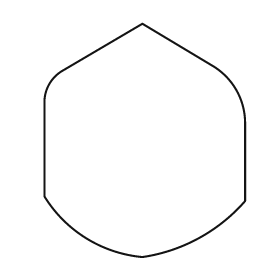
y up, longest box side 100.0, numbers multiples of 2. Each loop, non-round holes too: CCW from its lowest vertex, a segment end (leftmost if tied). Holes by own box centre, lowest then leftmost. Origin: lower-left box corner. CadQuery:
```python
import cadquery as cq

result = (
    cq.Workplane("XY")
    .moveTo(42.0, 0.0)
    .threePointArc((66.0, 8.0), (86.0, 24.0))
    .lineTo(86.0, 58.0)
    .threePointArc((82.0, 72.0), (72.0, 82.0))
    .lineTo(42.0, 100.0)
    .lineTo(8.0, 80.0)
    .threePointArc((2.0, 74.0), (0.0, 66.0))
    .lineTo(0.0, 26.0)
    .threePointArc((18.0, 8.0), (42.0, 0.0))
    .close()
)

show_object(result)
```